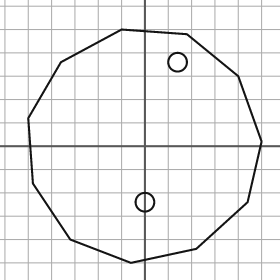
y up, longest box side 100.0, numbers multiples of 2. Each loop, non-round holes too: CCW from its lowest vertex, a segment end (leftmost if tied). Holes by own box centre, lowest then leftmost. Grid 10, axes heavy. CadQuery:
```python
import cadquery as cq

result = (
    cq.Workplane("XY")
    .moveTo(-6.0, -50.0)
    .lineTo(22.0, -44.0)
    .lineTo(44.0, -24.0)
    .lineTo(50.0, 2.0)
    .lineTo(40.0, 30.0)
    .lineTo(18.0, 48.0)
    .lineTo(-10.0, 50.0)
    .lineTo(-36.0, 36.0)
    .lineTo(-50.0, 12.0)
    .lineTo(-48.0, -16.0)
    .lineTo(-32.0, -40.0)
    .close()
    .moveTo(0.0, -24.0)
    .circle(4.0)
    .moveTo(14.0, 36.0)
    .circle(4.0)
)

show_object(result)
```